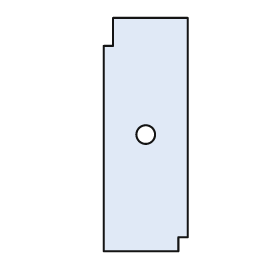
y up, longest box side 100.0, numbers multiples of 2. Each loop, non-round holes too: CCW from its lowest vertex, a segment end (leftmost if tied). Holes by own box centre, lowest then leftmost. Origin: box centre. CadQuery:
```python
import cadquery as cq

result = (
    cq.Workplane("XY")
    .moveTo(-18.0, -50.0)
    .lineTo(14.0, -50.0)
    .lineTo(14.0, -44.0)
    .lineTo(18.0, -44.0)
    .lineTo(18.0, 50.0)
    .lineTo(-14.0, 50.0)
    .lineTo(-14.0, 38.0)
    .lineTo(-18.0, 38.0)
    .close()
    .moveTo(0.0, 0.0)
    .circle(4.0)
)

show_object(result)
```